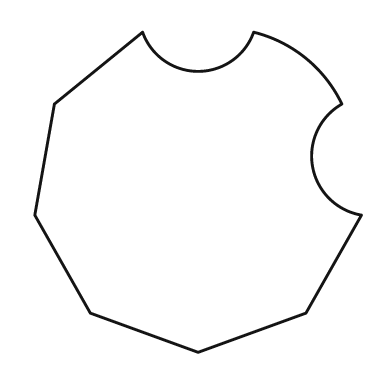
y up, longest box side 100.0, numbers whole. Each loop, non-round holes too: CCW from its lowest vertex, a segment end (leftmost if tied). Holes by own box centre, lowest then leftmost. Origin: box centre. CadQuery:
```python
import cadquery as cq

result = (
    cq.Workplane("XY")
    .moveTo(0.0, -49.0)
    .lineTo(33.0, -37.0)
    .lineTo(50.0, -7.0)
    .threePointArc((35.0, 8.0), (44.0, 27.0))
    .threePointArc((33.0, 41.0), (17.0, 49.0))
    .threePointArc((0.0, 37.0), (-17.0, 49.0))
    .lineTo(-44.0, 27.0)
    .lineTo(-50.0, -7.0)
    .lineTo(-33.0, -37.0)
    .close()
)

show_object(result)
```